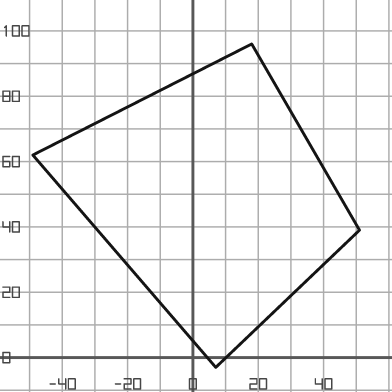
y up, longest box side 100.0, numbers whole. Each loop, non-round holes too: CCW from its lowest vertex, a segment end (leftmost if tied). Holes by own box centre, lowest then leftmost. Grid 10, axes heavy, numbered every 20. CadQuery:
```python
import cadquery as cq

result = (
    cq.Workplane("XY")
    .moveTo(7.0, -3.0)
    .lineTo(51.0, 39.0)
    .lineTo(18.0, 96.0)
    .lineTo(-49.0, 62.0)
    .close()
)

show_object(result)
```